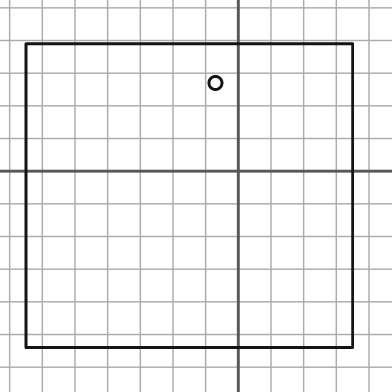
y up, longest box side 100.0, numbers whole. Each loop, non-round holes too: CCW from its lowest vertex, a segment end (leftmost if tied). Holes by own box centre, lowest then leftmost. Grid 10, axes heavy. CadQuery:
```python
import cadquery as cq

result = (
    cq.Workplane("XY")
    .moveTo(-65.0, -54.0)
    .lineTo(35.0, -54.0)
    .lineTo(35.0, 39.0)
    .lineTo(-65.0, 39.0)
    .close()
    .moveTo(-7.0, 27.0)
    .circle(2.0)
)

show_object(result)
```